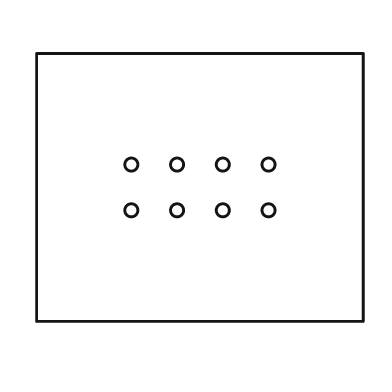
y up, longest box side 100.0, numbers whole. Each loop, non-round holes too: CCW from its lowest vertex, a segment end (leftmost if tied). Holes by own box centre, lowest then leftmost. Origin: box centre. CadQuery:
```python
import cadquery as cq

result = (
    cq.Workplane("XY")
    .moveTo(-50.0, -41.0)
    .lineTo(50.0, -41.0)
    .lineTo(50.0, 41.0)
    .lineTo(-50.0, 41.0)
    .close()
    .moveTo(-21.0, -7.0)
    .circle(2.0)
    .moveTo(-7.0, -7.0)
    .circle(2.0)
    .moveTo(7.0, -7.0)
    .circle(2.0)
    .moveTo(21.0, -7.0)
    .circle(2.0)
    .moveTo(-21.0, 7.0)
    .circle(2.0)
    .moveTo(-7.0, 7.0)
    .circle(2.0)
    .moveTo(7.0, 7.0)
    .circle(2.0)
    .moveTo(21.0, 7.0)
    .circle(2.0)
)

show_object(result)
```